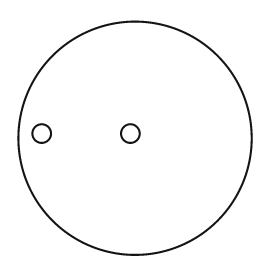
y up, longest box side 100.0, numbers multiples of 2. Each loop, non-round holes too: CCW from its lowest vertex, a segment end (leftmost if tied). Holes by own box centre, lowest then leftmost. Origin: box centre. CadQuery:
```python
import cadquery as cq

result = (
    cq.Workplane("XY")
    .moveTo(0.0, 0.0)
    .circle(50.0)
    .moveTo(-40.0, 2.0)
    .circle(4.0)
    .moveTo(-2.0, 2.0)
    .circle(4.0)
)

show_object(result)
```